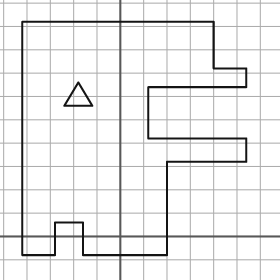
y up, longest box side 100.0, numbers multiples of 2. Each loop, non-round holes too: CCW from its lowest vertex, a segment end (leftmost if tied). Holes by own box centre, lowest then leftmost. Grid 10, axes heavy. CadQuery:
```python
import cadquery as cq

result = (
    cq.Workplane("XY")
    .moveTo(-42.0, -8.0)
    .lineTo(-28.0, -8.0)
    .lineTo(-28.0, 6.0)
    .lineTo(-16.0, 6.0)
    .lineTo(-16.0, -8.0)
    .lineTo(20.0, -8.0)
    .lineTo(20.0, 32.0)
    .lineTo(54.0, 32.0)
    .lineTo(54.0, 42.0)
    .lineTo(12.0, 42.0)
    .lineTo(12.0, 64.0)
    .lineTo(54.0, 64.0)
    .lineTo(54.0, 72.0)
    .lineTo(40.0, 72.0)
    .lineTo(40.0, 92.0)
    .lineTo(-42.0, 92.0)
    .close()
    .moveTo(-24.0, 56.0)
    .lineTo(-12.0, 56.0)
    .lineTo(-18.0, 66.0)
    .close()
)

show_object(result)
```